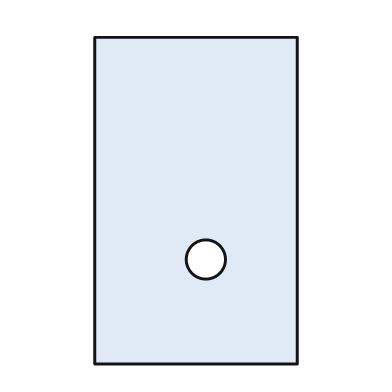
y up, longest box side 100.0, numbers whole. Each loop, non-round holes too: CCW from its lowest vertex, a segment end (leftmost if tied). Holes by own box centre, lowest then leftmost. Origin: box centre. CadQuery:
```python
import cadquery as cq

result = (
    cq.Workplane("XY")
    .moveTo(-31.0, -50.0)
    .lineTo(31.0, -50.0)
    .lineTo(31.0, 50.0)
    .lineTo(-31.0, 50.0)
    .close()
    .moveTo(3.0, -18.0)
    .circle(6.0)
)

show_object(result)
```